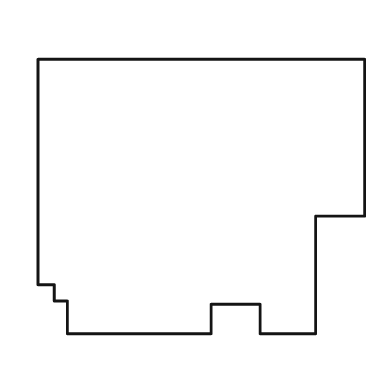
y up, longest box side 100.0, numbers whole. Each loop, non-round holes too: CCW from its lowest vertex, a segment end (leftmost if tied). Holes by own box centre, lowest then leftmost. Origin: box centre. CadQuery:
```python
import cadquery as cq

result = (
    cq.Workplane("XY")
    .moveTo(-41.0, -42.0)
    .lineTo(3.0, -42.0)
    .lineTo(3.0, -33.0)
    .lineTo(18.0, -33.0)
    .lineTo(18.0, -42.0)
    .lineTo(35.0, -42.0)
    .lineTo(35.0, -6.0)
    .lineTo(50.0, -6.0)
    .lineTo(50.0, 42.0)
    .lineTo(-50.0, 42.0)
    .lineTo(-50.0, -27.0)
    .lineTo(-45.0, -27.0)
    .lineTo(-45.0, -32.0)
    .lineTo(-41.0, -32.0)
    .close()
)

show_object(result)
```